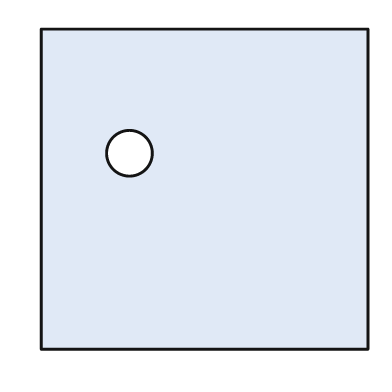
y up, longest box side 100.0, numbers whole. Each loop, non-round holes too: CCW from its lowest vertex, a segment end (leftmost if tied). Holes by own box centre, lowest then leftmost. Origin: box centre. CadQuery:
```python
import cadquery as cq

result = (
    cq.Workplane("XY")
    .moveTo(-50.0, -49.0)
    .lineTo(50.0, -49.0)
    .lineTo(50.0, 49.0)
    .lineTo(-50.0, 49.0)
    .close()
    .moveTo(-23.0, 11.0)
    .circle(7.0)
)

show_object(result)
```